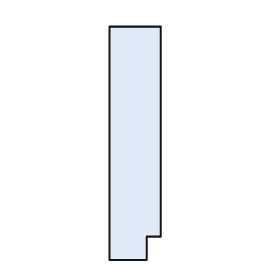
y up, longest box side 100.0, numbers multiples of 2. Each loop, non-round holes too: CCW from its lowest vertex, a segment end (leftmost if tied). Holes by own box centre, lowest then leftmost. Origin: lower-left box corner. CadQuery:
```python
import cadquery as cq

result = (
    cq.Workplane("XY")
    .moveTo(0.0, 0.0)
    .lineTo(16.0, 0.0)
    .lineTo(16.0, 10.0)
    .lineTo(22.0, 10.0)
    .lineTo(22.0, 100.0)
    .lineTo(0.0, 100.0)
    .close()
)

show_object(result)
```